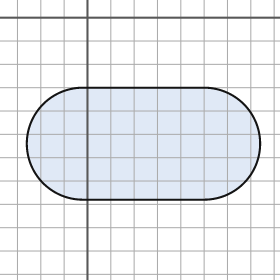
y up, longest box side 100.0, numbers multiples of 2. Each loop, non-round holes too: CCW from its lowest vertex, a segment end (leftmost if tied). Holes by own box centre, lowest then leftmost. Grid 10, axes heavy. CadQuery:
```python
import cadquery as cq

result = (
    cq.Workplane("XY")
    .moveTo(-2.0, -78.0)
    .lineTo(50.0, -78.0)
    .threePointArc((74.0, -54.0), (50.0, -30.0))
    .lineTo(-2.0, -30.0)
    .threePointArc((-26.0, -54.0), (-2.0, -78.0))
    .close()
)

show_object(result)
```